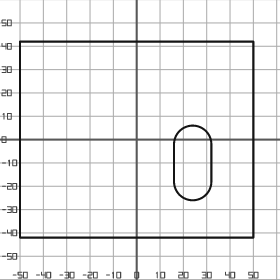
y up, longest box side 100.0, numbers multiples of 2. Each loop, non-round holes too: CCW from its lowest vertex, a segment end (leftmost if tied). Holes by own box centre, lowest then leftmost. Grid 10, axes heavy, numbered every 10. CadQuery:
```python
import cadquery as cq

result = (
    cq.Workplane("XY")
    .moveTo(-50.0, -42.0)
    .lineTo(50.0, -42.0)
    .lineTo(50.0, 42.0)
    .lineTo(-50.0, 42.0)
    .close()
    .moveTo(16.0, -18.0)
    .threePointArc((24.0, -26.0), (32.0, -18.0))
    .lineTo(32.0, -2.0)
    .threePointArc((24.0, 6.0), (16.0, -2.0))
    .close()
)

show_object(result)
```